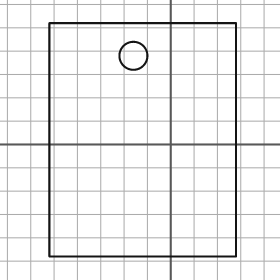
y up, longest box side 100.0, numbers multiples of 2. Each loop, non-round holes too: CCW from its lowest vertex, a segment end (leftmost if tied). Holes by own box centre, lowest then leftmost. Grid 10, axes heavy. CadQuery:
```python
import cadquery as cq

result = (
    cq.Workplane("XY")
    .moveTo(-52.0, -48.0)
    .lineTo(28.0, -48.0)
    .lineTo(28.0, 52.0)
    .lineTo(-52.0, 52.0)
    .close()
    .moveTo(-16.0, 38.0)
    .circle(6.0)
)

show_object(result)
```